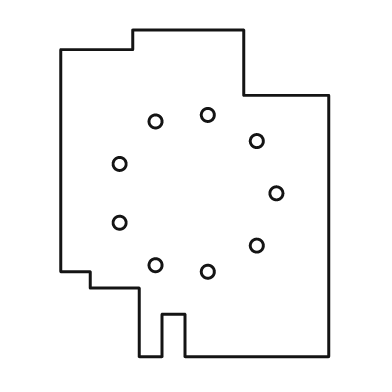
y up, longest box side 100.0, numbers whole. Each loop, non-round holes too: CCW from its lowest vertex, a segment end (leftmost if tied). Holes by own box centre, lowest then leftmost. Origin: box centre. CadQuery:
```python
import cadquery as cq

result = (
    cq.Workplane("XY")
    .moveTo(-17.0, -50.0)
    .lineTo(-10.0, -50.0)
    .lineTo(-10.0, -37.0)
    .lineTo(-3.0, -37.0)
    .lineTo(-3.0, -50.0)
    .lineTo(41.0, -50.0)
    .lineTo(41.0, 30.0)
    .lineTo(15.0, 30.0)
    .lineTo(15.0, 50.0)
    .lineTo(-19.0, 50.0)
    .lineTo(-19.0, 44.0)
    .lineTo(-41.0, 44.0)
    .lineTo(-41.0, -24.0)
    .lineTo(-32.0, -24.0)
    .lineTo(-32.0, -29.0)
    .lineTo(-17.0, -29.0)
    .close()
    .moveTo(4.0, -24.0)
    .circle(2.0)
    .moveTo(-12.0, -22.0)
    .circle(2.0)
    .moveTo(19.0, -16.0)
    .circle(2.0)
    .moveTo(-23.0, -9.0)
    .circle(2.0)
    .moveTo(25.0, 0.0)
    .circle(2.0)
    .moveTo(-23.0, 9.0)
    .circle(2.0)
    .moveTo(19.0, 16.0)
    .circle(2.0)
    .moveTo(-12.0, 22.0)
    .circle(2.0)
    .moveTo(4.0, 24.0)
    .circle(2.0)
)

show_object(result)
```